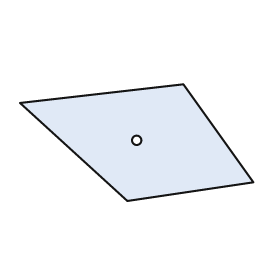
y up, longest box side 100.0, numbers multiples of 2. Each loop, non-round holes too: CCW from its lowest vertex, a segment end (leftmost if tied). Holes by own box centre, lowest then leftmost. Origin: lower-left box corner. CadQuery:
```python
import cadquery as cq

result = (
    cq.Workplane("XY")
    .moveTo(46.0, 0.0)
    .lineTo(100.0, 8.0)
    .lineTo(70.0, 50.0)
    .lineTo(0.0, 42.0)
    .close()
    .moveTo(50.0, 26.0)
    .circle(2.0)
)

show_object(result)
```